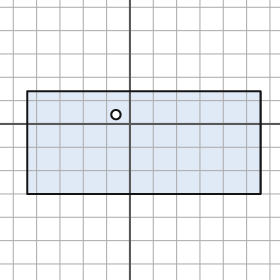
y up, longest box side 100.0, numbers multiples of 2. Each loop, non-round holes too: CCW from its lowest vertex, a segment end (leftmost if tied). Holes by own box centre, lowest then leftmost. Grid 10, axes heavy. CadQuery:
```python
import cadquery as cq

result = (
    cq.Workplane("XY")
    .moveTo(-44.0, -30.0)
    .lineTo(56.0, -30.0)
    .lineTo(56.0, 14.0)
    .lineTo(-44.0, 14.0)
    .close()
    .moveTo(-6.0, 4.0)
    .circle(2.0)
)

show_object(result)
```